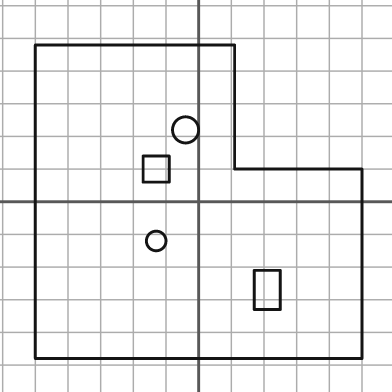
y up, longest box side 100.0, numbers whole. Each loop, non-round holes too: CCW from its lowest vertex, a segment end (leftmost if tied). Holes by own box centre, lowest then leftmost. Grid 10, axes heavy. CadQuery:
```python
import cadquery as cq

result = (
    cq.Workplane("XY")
    .moveTo(-50.0, -48.0)
    .lineTo(50.0, -48.0)
    .lineTo(50.0, 10.0)
    .lineTo(11.0, 10.0)
    .lineTo(11.0, 48.0)
    .lineTo(-50.0, 48.0)
    .close()
    .moveTo(17.0, -33.0)
    .lineTo(25.0, -33.0)
    .lineTo(25.0, -21.0)
    .lineTo(17.0, -21.0)
    .close()
    .moveTo(-13.0, -12.0)
    .circle(3.0)
    .moveTo(-17.0, 6.0)
    .lineTo(-9.0, 6.0)
    .lineTo(-9.0, 14.0)
    .lineTo(-17.0, 14.0)
    .close()
    .moveTo(-4.0, 22.0)
    .circle(4.0)
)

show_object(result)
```